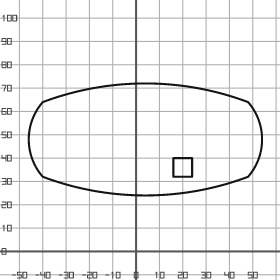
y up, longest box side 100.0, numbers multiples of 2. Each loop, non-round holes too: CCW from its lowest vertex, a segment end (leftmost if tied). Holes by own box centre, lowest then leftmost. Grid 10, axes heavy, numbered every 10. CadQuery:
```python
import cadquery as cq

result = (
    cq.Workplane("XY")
    .moveTo(-40.0, 32.0)
    .threePointArc((4.0, 24.0), (48.0, 32.0))
    .threePointArc((54.0, 48.0), (48.0, 64.0))
    .threePointArc((4.0, 72.0), (-40.0, 64.0))
    .threePointArc((-46.0, 48.0), (-40.0, 32.0))
    .close()
    .moveTo(16.0, 32.0)
    .lineTo(24.0, 32.0)
    .lineTo(24.0, 40.0)
    .lineTo(16.0, 40.0)
    .close()
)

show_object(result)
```